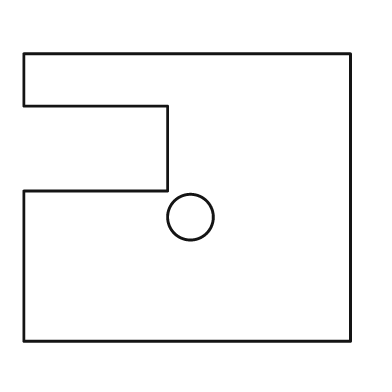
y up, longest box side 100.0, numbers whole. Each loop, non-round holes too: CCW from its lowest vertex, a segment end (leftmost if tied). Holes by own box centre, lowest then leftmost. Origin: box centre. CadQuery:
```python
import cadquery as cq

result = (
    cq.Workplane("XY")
    .moveTo(-50.0, -44.0)
    .lineTo(50.0, -44.0)
    .lineTo(50.0, 44.0)
    .lineTo(-50.0, 44.0)
    .lineTo(-50.0, 28.0)
    .lineTo(-6.0, 28.0)
    .lineTo(-6.0, 2.0)
    .lineTo(-50.0, 2.0)
    .close()
    .moveTo(1.0, -6.0)
    .circle(7.0)
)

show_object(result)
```